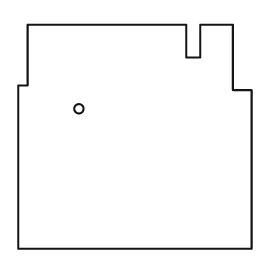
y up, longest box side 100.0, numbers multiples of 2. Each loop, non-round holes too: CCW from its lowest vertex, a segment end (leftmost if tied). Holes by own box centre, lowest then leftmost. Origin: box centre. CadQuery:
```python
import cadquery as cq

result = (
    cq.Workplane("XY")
    .moveTo(-50.0, -48.0)
    .lineTo(50.0, -48.0)
    .lineTo(50.0, 20.0)
    .lineTo(42.0, 20.0)
    .lineTo(42.0, 48.0)
    .lineTo(28.0, 48.0)
    .lineTo(28.0, 34.0)
    .lineTo(22.0, 34.0)
    .lineTo(22.0, 48.0)
    .lineTo(-46.0, 48.0)
    .lineTo(-46.0, 22.0)
    .lineTo(-50.0, 22.0)
    .close()
    .moveTo(-24.0, 12.0)
    .circle(2.0)
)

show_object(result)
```